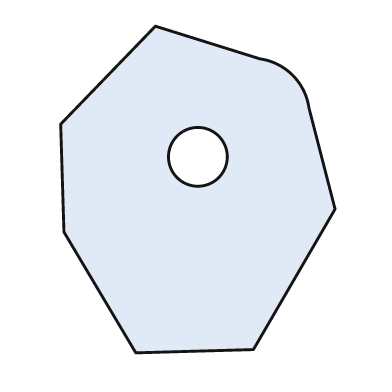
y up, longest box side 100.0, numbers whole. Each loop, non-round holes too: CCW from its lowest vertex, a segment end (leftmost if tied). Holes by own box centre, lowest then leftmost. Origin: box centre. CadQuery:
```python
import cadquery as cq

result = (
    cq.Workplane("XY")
    .moveTo(-19.0, -50.0)
    .lineTo(17.0, -49.0)
    .lineTo(42.0, -6.0)
    .lineTo(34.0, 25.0)
    .threePointArc((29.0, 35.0), (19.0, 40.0))
    .lineTo(-13.0, 50.0)
    .lineTo(-42.0, 20.0)
    .lineTo(-41.0, -13.0)
    .close()
    .moveTo(0.0, 10.0)
    .circle(9.0)
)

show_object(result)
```